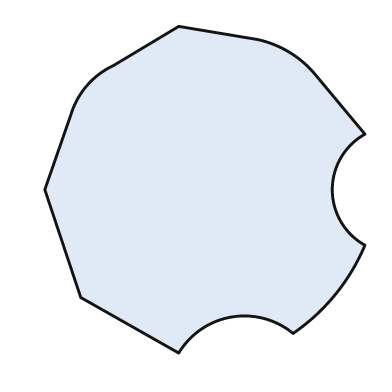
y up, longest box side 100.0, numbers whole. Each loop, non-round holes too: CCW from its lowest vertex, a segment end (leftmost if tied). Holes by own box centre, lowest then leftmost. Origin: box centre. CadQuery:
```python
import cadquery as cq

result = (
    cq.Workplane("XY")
    .moveTo(-8.0, -50.0)
    .threePointArc((8.0, -39.0), (27.0, -44.0))
    .threePointArc((40.0, -32.0), (49.0, -17.0))
    .threePointArc((39.0, 0.0), (49.0, 17.0))
    .lineTo(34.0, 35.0)
    .threePointArc((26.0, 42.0), (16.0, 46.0))
    .lineTo(-8.0, 50.0)
    .lineTo(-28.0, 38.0)
    .threePointArc((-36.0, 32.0), (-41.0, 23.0))
    .lineTo(-49.0, 0.0)
    .lineTo(-38.0, -33.0)
    .close()
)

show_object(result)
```